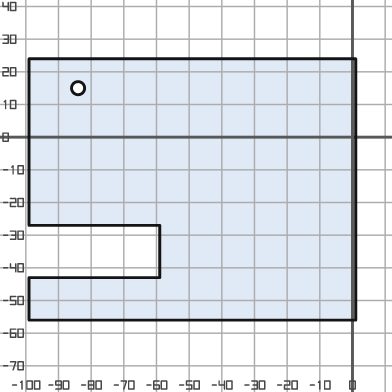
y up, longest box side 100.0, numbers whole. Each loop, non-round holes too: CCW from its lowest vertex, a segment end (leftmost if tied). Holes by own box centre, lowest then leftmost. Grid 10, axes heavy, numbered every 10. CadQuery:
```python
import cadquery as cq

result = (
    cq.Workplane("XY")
    .moveTo(-99.0, -56.0)
    .lineTo(1.0, -56.0)
    .lineTo(1.0, 24.0)
    .lineTo(-99.0, 24.0)
    .lineTo(-99.0, -27.0)
    .lineTo(-59.0, -27.0)
    .lineTo(-59.0, -43.0)
    .lineTo(-99.0, -43.0)
    .close()
    .moveTo(-84.0, 15.0)
    .circle(2.0)
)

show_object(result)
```